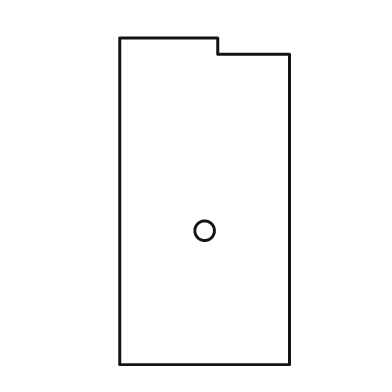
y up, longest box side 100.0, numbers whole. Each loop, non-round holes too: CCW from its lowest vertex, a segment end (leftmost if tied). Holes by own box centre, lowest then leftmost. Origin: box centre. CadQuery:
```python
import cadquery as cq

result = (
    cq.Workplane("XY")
    .moveTo(-26.0, -50.0)
    .lineTo(26.0, -50.0)
    .lineTo(26.0, 45.0)
    .lineTo(4.0, 45.0)
    .lineTo(4.0, 50.0)
    .lineTo(-26.0, 50.0)
    .close()
    .moveTo(0.0, -9.0)
    .circle(3.0)
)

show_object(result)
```